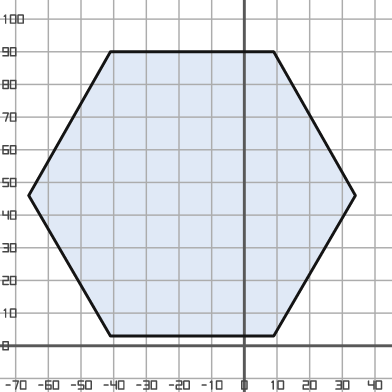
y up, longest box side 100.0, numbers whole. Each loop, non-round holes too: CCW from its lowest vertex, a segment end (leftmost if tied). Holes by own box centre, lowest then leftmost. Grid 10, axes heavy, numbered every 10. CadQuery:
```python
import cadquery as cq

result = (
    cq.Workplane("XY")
    .moveTo(-41.0, 3.0)
    .lineTo(9.0, 3.0)
    .lineTo(34.0, 46.0)
    .lineTo(9.0, 90.0)
    .lineTo(-41.0, 90.0)
    .lineTo(-66.0, 46.0)
    .close()
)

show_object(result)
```